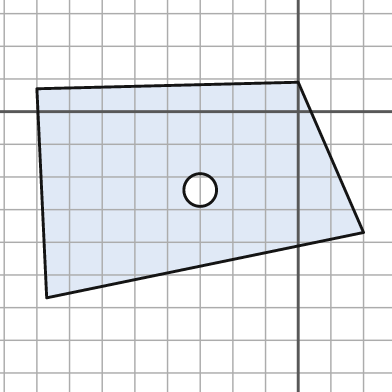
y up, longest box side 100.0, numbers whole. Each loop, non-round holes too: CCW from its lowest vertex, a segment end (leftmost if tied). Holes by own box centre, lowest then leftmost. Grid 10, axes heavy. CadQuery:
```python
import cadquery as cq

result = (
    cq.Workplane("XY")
    .moveTo(-77.0, -57.0)
    .lineTo(20.0, -37.0)
    .lineTo(0.0, 9.0)
    .lineTo(-80.0, 7.0)
    .close()
    .moveTo(-30.0, -24.0)
    .circle(5.0)
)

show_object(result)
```